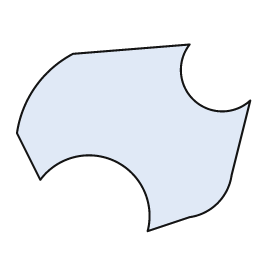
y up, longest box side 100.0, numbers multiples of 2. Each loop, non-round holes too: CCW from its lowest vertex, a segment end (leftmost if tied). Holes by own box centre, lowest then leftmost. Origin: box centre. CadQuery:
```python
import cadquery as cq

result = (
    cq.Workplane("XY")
    .moveTo(6.0, -40.0)
    .lineTo(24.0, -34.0)
    .threePointArc((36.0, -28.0), (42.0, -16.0))
    .lineTo(50.0, 16.0)
    .threePointArc((26.0, 16.0), (24.0, 40.0))
    .lineTo(-26.0, 36.0)
    .threePointArc((-42.0, 22.0), (-50.0, 2.0))
    .lineTo(-40.0, -18.0)
    .threePointArc((-8.0, -10.0), (6.0, -40.0))
    .close()
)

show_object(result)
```